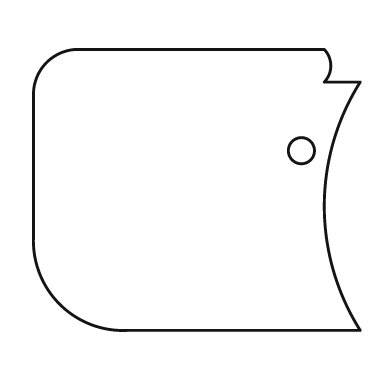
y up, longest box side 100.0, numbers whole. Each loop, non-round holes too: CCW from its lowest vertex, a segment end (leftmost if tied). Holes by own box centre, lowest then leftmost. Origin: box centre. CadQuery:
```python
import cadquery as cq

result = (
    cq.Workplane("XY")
    .moveTo(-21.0, -43.0)
    .lineTo(50.0, -43.0)
    .threePointArc((39.0, -5.0), (50.0, 33.0))
    .lineTo(39.0, 33.0)
    .threePointArc((41.0, 38.0), (39.0, 43.0))
    .lineTo(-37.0, 43.0)
    .threePointArc((-46.0, 39.0), (-50.0, 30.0))
    .lineTo(-50.0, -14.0)
    .threePointArc((-42.0, -35.0), (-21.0, -43.0))
    .close()
    .moveTo(32.0, 12.0)
    .circle(4.0)
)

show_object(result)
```